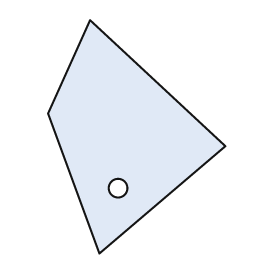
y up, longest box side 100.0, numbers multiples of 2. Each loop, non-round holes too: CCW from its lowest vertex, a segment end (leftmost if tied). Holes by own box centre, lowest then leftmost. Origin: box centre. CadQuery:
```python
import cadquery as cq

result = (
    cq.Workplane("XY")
    .moveTo(-16.0, -50.0)
    .lineTo(38.0, -4.0)
    .lineTo(-20.0, 50.0)
    .lineTo(-38.0, 10.0)
    .close()
    .moveTo(-8.0, -22.0)
    .circle(4.0)
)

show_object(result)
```